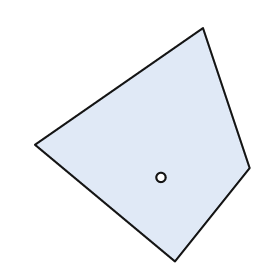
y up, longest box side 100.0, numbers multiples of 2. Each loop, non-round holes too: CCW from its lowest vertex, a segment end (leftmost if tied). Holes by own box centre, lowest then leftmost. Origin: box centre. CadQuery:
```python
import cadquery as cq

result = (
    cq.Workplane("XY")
    .moveTo(14.0, -50.0)
    .lineTo(46.0, -10.0)
    .lineTo(26.0, 50.0)
    .lineTo(-46.0, 0.0)
    .close()
    .moveTo(8.0, -14.0)
    .circle(2.0)
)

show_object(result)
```